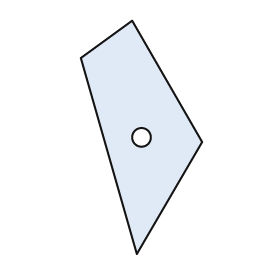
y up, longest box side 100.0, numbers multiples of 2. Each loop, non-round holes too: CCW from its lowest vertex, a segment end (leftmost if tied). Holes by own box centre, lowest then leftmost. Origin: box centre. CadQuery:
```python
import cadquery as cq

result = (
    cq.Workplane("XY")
    .moveTo(-2.0, -50.0)
    .lineTo(26.0, -2.0)
    .lineTo(-4.0, 50.0)
    .lineTo(-26.0, 34.0)
    .close()
    .moveTo(0.0, 0.0)
    .circle(4.0)
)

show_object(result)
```